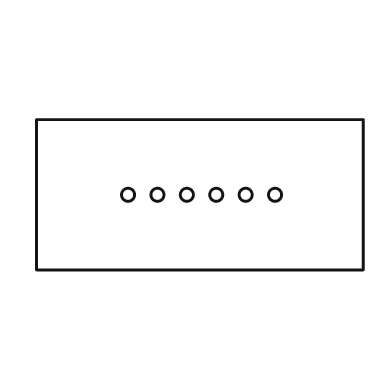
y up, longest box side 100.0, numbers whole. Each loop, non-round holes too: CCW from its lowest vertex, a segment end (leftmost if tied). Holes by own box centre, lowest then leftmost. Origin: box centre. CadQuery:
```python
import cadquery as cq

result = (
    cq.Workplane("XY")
    .moveTo(-50.0, -23.0)
    .lineTo(50.0, -23.0)
    .lineTo(50.0, 23.0)
    .lineTo(-50.0, 23.0)
    .close()
    .moveTo(-22.0, 0.0)
    .circle(2.0)
    .moveTo(-13.0, 0.0)
    .circle(2.0)
    .moveTo(-4.0, 0.0)
    .circle(2.0)
    .moveTo(5.0, 0.0)
    .circle(2.0)
    .moveTo(14.0, 0.0)
    .circle(2.0)
    .moveTo(23.0, 0.0)
    .circle(2.0)
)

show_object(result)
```